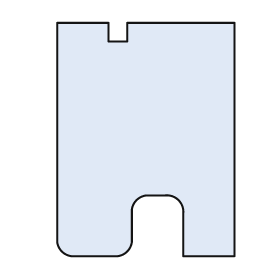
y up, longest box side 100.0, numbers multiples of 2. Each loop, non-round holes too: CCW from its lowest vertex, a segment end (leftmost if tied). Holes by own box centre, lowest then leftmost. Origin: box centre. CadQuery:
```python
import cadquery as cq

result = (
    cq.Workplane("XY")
    .moveTo(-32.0, -50.0)
    .lineTo(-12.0, -50.0)
    .threePointArc((-8.0, -48.0), (-6.0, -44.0))
    .lineTo(-6.0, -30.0)
    .threePointArc((-4.0, -26.0), (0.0, -24.0))
    .lineTo(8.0, -24.0)
    .threePointArc((14.0, -26.0), (16.0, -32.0))
    .lineTo(16.0, -50.0)
    .lineTo(38.0, -50.0)
    .lineTo(38.0, 50.0)
    .lineTo(-8.0, 50.0)
    .lineTo(-8.0, 42.0)
    .lineTo(-16.0, 42.0)
    .lineTo(-16.0, 50.0)
    .lineTo(-38.0, 50.0)
    .lineTo(-38.0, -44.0)
    .threePointArc((-36.0, -48.0), (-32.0, -50.0))
    .close()
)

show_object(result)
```